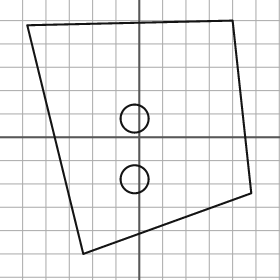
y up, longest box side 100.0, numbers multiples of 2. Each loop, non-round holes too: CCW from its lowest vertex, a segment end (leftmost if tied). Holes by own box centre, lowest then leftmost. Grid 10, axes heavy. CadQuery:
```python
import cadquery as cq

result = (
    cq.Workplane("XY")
    .moveTo(-24.0, -50.0)
    .lineTo(48.0, -24.0)
    .lineTo(40.0, 50.0)
    .lineTo(-48.0, 48.0)
    .close()
    .moveTo(-2.0, -18.0)
    .circle(6.0)
    .moveTo(-2.0, 8.0)
    .circle(6.0)
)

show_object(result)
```